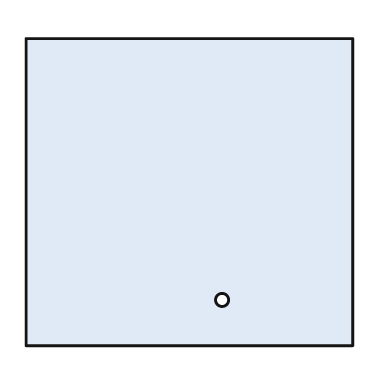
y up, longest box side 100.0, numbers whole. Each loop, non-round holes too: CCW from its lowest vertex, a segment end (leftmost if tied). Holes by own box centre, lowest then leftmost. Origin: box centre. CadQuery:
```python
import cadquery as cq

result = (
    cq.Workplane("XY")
    .moveTo(-50.0, -47.0)
    .lineTo(50.0, -47.0)
    .lineTo(50.0, 47.0)
    .lineTo(-50.0, 47.0)
    .close()
    .moveTo(10.0, -33.0)
    .circle(2.0)
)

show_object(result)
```